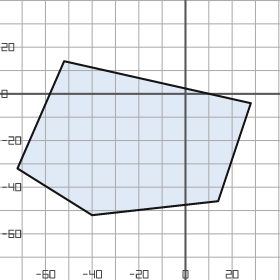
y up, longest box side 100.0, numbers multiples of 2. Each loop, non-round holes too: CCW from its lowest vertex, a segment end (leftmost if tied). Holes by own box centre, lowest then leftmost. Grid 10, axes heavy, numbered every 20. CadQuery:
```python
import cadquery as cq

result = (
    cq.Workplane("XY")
    .moveTo(-40.0, -52.0)
    .lineTo(14.0, -46.0)
    .lineTo(28.0, -4.0)
    .lineTo(-52.0, 14.0)
    .lineTo(-72.0, -32.0)
    .close()
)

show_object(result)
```